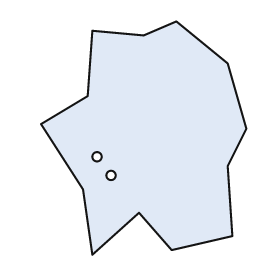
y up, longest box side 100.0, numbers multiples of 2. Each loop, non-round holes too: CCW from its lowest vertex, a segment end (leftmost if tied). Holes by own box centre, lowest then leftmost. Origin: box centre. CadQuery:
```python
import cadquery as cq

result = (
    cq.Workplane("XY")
    .moveTo(-22.0, -50.0)
    .lineTo(-2.0, -32.0)
    .lineTo(12.0, -48.0)
    .lineTo(38.0, -42.0)
    .lineTo(36.0, -12.0)
    .lineTo(44.0, 4.0)
    .lineTo(36.0, 32.0)
    .lineTo(14.0, 50.0)
    .lineTo(0.0, 44.0)
    .lineTo(-22.0, 46.0)
    .lineTo(-24.0, 18.0)
    .lineTo(-44.0, 6.0)
    .lineTo(-26.0, -22.0)
    .close()
    .moveTo(-14.0, -16.0)
    .circle(2.0)
    .moveTo(-20.0, -8.0)
    .circle(2.0)
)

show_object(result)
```